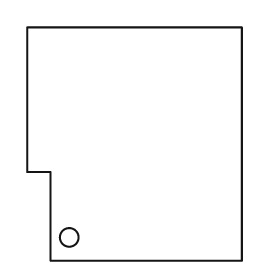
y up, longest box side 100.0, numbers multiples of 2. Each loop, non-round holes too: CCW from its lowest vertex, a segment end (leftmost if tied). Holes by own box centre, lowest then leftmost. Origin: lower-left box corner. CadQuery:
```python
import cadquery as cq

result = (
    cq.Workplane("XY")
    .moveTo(10.0, 0.0)
    .lineTo(92.0, 0.0)
    .lineTo(92.0, 100.0)
    .lineTo(0.0, 100.0)
    .lineTo(0.0, 38.0)
    .lineTo(10.0, 38.0)
    .close()
    .moveTo(18.0, 10.0)
    .circle(4.0)
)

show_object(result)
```